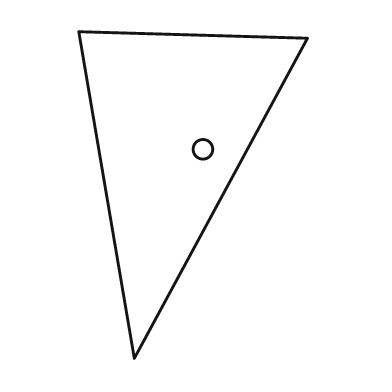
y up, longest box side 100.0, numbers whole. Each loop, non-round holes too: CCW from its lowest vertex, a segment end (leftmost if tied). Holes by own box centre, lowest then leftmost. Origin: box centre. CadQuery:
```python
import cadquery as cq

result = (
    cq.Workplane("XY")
    .moveTo(-18.0, -50.0)
    .lineTo(35.0, 48.0)
    .lineTo(-35.0, 50.0)
    .close()
    .moveTo(3.0, 14.0)
    .circle(3.0)
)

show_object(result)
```